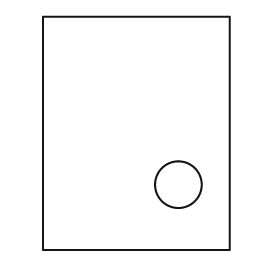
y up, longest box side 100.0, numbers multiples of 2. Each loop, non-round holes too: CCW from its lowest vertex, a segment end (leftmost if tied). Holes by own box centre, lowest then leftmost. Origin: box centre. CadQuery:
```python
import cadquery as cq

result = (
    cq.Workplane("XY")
    .moveTo(-40.0, -50.0)
    .lineTo(40.0, -50.0)
    .lineTo(40.0, 50.0)
    .lineTo(-40.0, 50.0)
    .close()
    .moveTo(18.0, -22.0)
    .circle(10.0)
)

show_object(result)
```